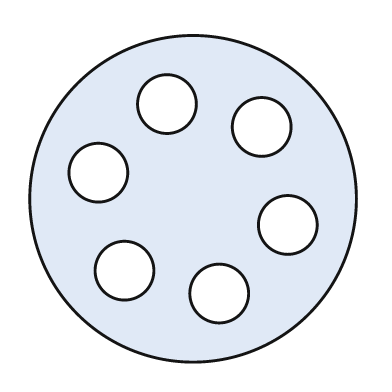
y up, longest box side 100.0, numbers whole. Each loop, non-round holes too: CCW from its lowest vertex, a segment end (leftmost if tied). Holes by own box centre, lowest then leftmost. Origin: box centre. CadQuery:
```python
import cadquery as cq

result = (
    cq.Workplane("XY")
    .moveTo(0.0, 0.0)
    .circle(50.0)
    .moveTo(8.0, -29.0)
    .circle(9.0)
    .moveTo(-21.0, -22.0)
    .circle(9.0)
    .moveTo(29.0, -8.0)
    .circle(9.0)
    .moveTo(-29.0, 8.0)
    .circle(9.0)
    .moveTo(21.0, 22.0)
    .circle(9.0)
    .moveTo(-8.0, 29.0)
    .circle(9.0)
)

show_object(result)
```